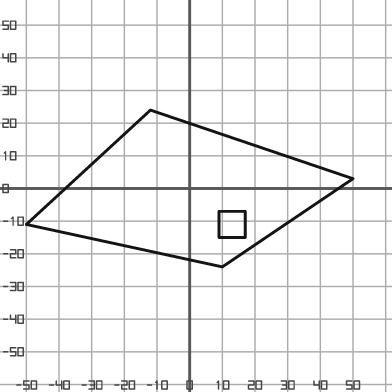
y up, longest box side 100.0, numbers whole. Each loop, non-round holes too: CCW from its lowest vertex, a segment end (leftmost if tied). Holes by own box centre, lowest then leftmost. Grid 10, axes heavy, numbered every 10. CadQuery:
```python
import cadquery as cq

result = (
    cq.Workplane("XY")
    .moveTo(10.0, -24.0)
    .lineTo(50.0, 3.0)
    .lineTo(-12.0, 24.0)
    .lineTo(-50.0, -11.0)
    .close()
    .moveTo(9.0, -15.0)
    .lineTo(17.0, -15.0)
    .lineTo(17.0, -7.0)
    .lineTo(9.0, -7.0)
    .close()
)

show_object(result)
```